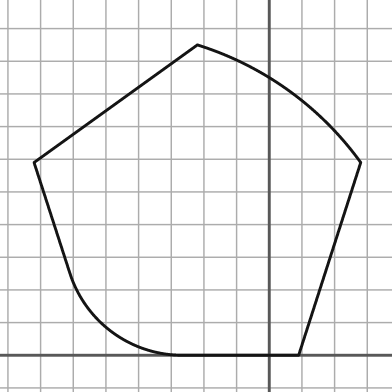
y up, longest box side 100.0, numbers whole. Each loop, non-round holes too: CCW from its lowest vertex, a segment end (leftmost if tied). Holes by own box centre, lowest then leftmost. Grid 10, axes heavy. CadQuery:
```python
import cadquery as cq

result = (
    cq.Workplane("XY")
    .moveTo(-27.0, 0.0)
    .lineTo(9.0, 0.0)
    .lineTo(28.0, 59.0)
    .threePointArc((6.0, 81.0), (-22.0, 95.0))
    .lineTo(-72.0, 59.0)
    .lineTo(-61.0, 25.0)
    .threePointArc((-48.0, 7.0), (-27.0, 0.0))
    .close()
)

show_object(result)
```